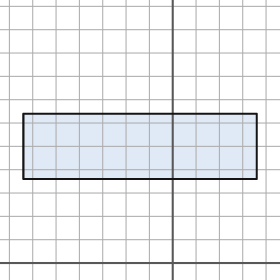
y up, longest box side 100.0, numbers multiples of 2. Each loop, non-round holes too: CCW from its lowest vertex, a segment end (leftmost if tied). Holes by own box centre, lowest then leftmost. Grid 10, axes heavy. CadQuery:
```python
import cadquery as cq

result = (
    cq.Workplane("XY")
    .moveTo(-64.0, 36.0)
    .lineTo(36.0, 36.0)
    .lineTo(36.0, 64.0)
    .lineTo(-64.0, 64.0)
    .close()
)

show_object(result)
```